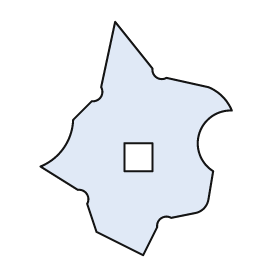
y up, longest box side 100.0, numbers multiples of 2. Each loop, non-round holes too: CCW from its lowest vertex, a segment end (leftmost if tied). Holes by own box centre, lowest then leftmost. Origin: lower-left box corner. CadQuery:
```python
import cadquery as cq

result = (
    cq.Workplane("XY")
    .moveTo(44.0, 0.0)
    .lineTo(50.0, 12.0)
    .threePointArc((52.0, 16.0), (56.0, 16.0))
    .lineTo(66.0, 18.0)
    .threePointArc((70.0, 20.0), (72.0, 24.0))
    .lineTo(74.0, 36.0)
    .threePointArc((68.0, 52.0), (82.0, 62.0))
    .threePointArc((78.0, 68.0), (72.0, 72.0))
    .lineTo(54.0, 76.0)
    .threePointArc((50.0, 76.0), (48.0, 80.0))
    .lineTo(32.0, 100.0)
    .lineTo(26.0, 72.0)
    .threePointArc((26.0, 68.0), (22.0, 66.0))
    .lineTo(14.0, 58.0)
    .threePointArc((10.0, 46.0), (0.0, 38.0))
    .lineTo(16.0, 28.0)
    .threePointArc((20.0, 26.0), (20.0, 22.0))
    .lineTo(24.0, 10.0)
    .close()
    .moveTo(36.0, 36.0)
    .lineTo(48.0, 36.0)
    .lineTo(48.0, 48.0)
    .lineTo(36.0, 48.0)
    .close()
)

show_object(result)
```